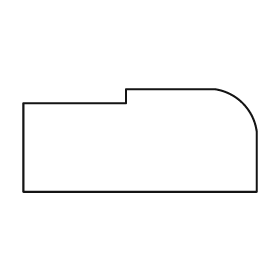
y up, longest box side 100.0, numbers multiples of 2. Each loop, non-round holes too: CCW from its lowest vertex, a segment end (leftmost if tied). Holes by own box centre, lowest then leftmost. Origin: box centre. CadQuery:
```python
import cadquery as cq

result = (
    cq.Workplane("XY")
    .moveTo(-50.0, -22.0)
    .lineTo(50.0, -22.0)
    .lineTo(50.0, 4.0)
    .threePointArc((44.0, 16.0), (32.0, 22.0))
    .lineTo(-6.0, 22.0)
    .lineTo(-6.0, 16.0)
    .lineTo(-50.0, 16.0)
    .close()
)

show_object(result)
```